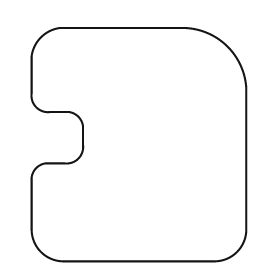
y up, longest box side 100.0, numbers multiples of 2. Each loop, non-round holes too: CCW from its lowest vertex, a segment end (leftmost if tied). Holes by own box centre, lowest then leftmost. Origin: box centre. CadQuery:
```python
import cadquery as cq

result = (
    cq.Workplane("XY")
    .moveTo(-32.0, -50.0)
    .lineTo(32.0, -50.0)
    .threePointArc((42.0, -46.0), (46.0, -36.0))
    .lineTo(46.0, 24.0)
    .threePointArc((38.0, 42.0), (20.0, 50.0))
    .lineTo(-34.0, 50.0)
    .threePointArc((-42.0, 46.0), (-46.0, 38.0))
    .lineTo(-46.0, 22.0)
    .threePointArc((-44.0, 16.0), (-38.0, 14.0))
    .lineTo(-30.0, 14.0)
    .threePointArc((-26.0, 12.0), (-24.0, 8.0))
    .lineTo(-24.0, 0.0)
    .threePointArc((-26.0, -6.0), (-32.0, -8.0))
    .lineTo(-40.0, -8.0)
    .threePointArc((-44.0, -10.0), (-46.0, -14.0))
    .lineTo(-46.0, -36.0)
    .threePointArc((-42.0, -46.0), (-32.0, -50.0))
    .close()
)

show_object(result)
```